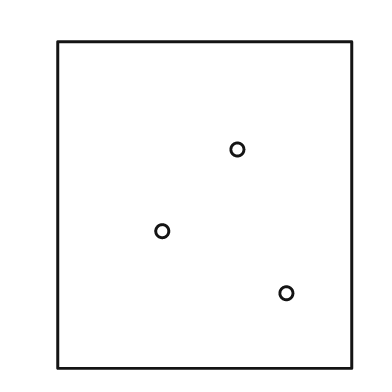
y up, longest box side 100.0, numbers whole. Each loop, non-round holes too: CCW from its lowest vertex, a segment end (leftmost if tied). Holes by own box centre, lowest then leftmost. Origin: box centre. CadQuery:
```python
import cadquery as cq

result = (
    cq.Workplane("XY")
    .moveTo(-45.0, -50.0)
    .lineTo(45.0, -50.0)
    .lineTo(45.0, 50.0)
    .lineTo(-45.0, 50.0)
    .close()
    .moveTo(25.0, -27.0)
    .circle(2.0)
    .moveTo(-13.0, -8.0)
    .circle(2.0)
    .moveTo(10.0, 17.0)
    .circle(2.0)
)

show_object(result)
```